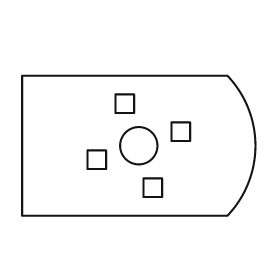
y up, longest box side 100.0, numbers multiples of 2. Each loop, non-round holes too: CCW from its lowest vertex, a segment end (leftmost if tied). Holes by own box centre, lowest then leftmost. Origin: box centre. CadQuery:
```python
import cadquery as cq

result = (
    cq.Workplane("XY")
    .moveTo(-50.0, -30.0)
    .lineTo(38.0, -30.0)
    .threePointArc((50.0, 0.0), (38.0, 30.0))
    .lineTo(-50.0, 30.0)
    .close()
    .moveTo(2.0, -22.0)
    .lineTo(10.0, -22.0)
    .lineTo(10.0, -14.0)
    .lineTo(2.0, -14.0)
    .close()
    .moveTo(-22.0, -10.0)
    .lineTo(-14.0, -10.0)
    .lineTo(-14.0, -2.0)
    .lineTo(-22.0, -2.0)
    .close()
    .moveTo(0.0, 0.0)
    .circle(8.0)
    .moveTo(14.0, 2.0)
    .lineTo(22.0, 2.0)
    .lineTo(22.0, 10.0)
    .lineTo(14.0, 10.0)
    .close()
    .moveTo(-10.0, 14.0)
    .lineTo(-2.0, 14.0)
    .lineTo(-2.0, 22.0)
    .lineTo(-10.0, 22.0)
    .close()
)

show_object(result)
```